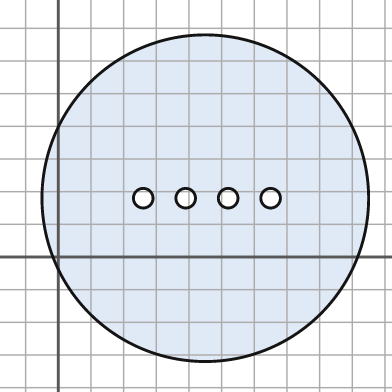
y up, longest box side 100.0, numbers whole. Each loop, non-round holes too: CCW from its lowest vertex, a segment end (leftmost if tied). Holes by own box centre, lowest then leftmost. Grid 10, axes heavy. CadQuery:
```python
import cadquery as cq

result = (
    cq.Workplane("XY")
    .moveTo(45.0, 18.0)
    .circle(50.0)
    .moveTo(26.0, 18.0)
    .circle(3.0)
    .moveTo(39.0, 18.0)
    .circle(3.0)
    .moveTo(52.0, 18.0)
    .circle(3.0)
    .moveTo(65.0, 18.0)
    .circle(3.0)
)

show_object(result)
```